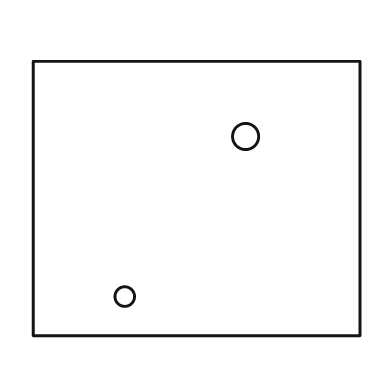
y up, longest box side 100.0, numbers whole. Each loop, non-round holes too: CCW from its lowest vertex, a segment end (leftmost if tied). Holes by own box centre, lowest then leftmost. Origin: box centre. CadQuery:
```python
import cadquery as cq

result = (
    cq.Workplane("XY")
    .moveTo(-50.0, -42.0)
    .lineTo(50.0, -42.0)
    .lineTo(50.0, 42.0)
    .lineTo(-50.0, 42.0)
    .close()
    .moveTo(-22.0, -30.0)
    .circle(3.0)
    .moveTo(15.0, 19.0)
    .circle(4.0)
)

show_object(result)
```